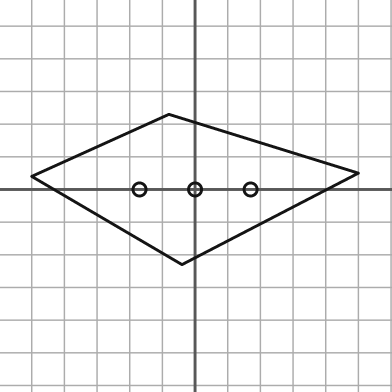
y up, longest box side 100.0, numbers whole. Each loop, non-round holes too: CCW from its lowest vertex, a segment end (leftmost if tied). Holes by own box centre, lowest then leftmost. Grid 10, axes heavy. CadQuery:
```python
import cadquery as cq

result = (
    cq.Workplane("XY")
    .moveTo(-4.0, -23.0)
    .lineTo(50.0, 5.0)
    .lineTo(-8.0, 23.0)
    .lineTo(-50.0, 4.0)
    .close()
    .moveTo(-17.0, 0.0)
    .circle(2.0)
    .moveTo(0.0, 0.0)
    .circle(2.0)
    .moveTo(17.0, 0.0)
    .circle(2.0)
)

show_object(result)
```